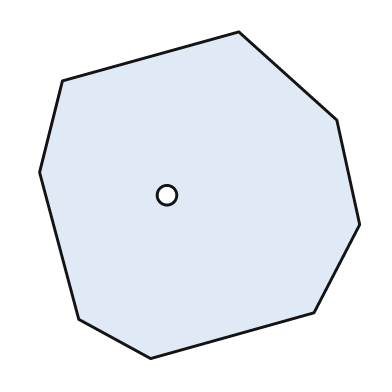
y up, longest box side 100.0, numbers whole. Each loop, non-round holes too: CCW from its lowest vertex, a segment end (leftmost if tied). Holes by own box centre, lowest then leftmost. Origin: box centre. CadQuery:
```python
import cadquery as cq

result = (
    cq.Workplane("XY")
    .moveTo(-15.0, -50.0)
    .lineTo(35.0, -36.0)
    .lineTo(49.0, -9.0)
    .lineTo(42.0, 23.0)
    .lineTo(12.0, 50.0)
    .lineTo(-42.0, 35.0)
    .lineTo(-49.0, 7.0)
    .lineTo(-37.0, -38.0)
    .close()
    .moveTo(-10.0, 0.0)
    .circle(3.0)
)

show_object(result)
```